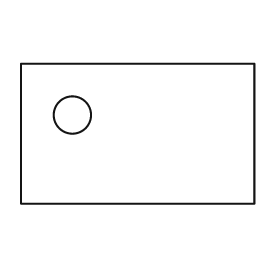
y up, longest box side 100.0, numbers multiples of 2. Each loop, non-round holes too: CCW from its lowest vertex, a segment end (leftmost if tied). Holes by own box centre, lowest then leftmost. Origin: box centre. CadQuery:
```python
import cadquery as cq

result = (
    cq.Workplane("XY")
    .moveTo(-50.0, -30.0)
    .lineTo(50.0, -30.0)
    .lineTo(50.0, 30.0)
    .lineTo(-50.0, 30.0)
    .close()
    .moveTo(-28.0, 8.0)
    .circle(8.0)
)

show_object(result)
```